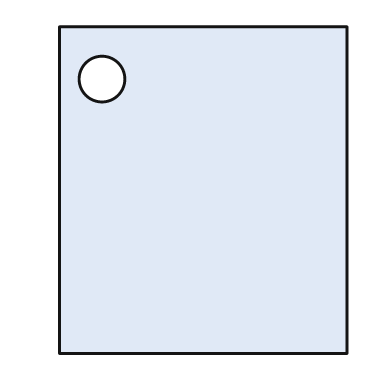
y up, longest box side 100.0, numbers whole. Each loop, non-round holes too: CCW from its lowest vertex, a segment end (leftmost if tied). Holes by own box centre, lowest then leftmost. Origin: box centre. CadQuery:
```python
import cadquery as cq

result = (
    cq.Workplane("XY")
    .moveTo(-44.0, -50.0)
    .lineTo(44.0, -50.0)
    .lineTo(44.0, 50.0)
    .lineTo(-44.0, 50.0)
    .close()
    .moveTo(-31.0, 34.0)
    .circle(7.0)
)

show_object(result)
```